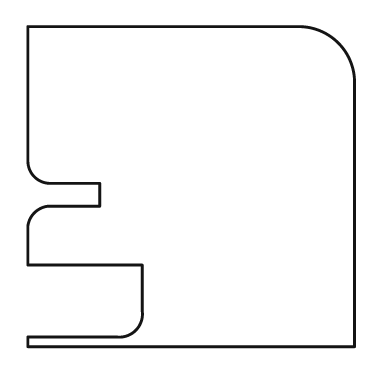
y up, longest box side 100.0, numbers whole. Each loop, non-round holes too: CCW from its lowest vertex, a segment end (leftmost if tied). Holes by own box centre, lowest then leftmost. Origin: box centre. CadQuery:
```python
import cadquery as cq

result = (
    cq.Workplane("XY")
    .moveTo(-50.0, -49.0)
    .lineTo(50.0, -49.0)
    .lineTo(50.0, 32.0)
    .threePointArc((45.0, 44.0), (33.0, 49.0))
    .lineTo(-50.0, 49.0)
    .lineTo(-50.0, 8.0)
    .threePointArc((-48.0, 3.0), (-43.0, 1.0))
    .lineTo(-28.0, 1.0)
    .lineTo(-28.0, -6.0)
    .lineTo(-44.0, -6.0)
    .threePointArc((-48.0, -8.0), (-50.0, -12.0))
    .lineTo(-50.0, -24.0)
    .lineTo(-15.0, -24.0)
    .lineTo(-15.0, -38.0)
    .threePointArc((-17.0, -44.0), (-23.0, -46.0))
    .lineTo(-50.0, -46.0)
    .close()
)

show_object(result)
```